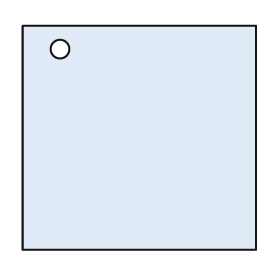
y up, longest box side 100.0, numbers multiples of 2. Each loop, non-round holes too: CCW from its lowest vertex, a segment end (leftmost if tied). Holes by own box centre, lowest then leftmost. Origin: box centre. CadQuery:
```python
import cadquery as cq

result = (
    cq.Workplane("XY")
    .moveTo(-50.0, -48.0)
    .lineTo(50.0, -48.0)
    .lineTo(50.0, 48.0)
    .lineTo(-50.0, 48.0)
    .close()
    .moveTo(-34.0, 38.0)
    .circle(4.0)
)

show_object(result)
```